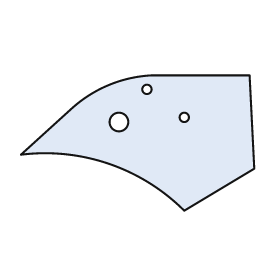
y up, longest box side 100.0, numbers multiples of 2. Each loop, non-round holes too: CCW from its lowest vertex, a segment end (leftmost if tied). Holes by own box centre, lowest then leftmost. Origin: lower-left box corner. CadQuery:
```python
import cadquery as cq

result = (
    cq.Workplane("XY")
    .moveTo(70.0, 0.0)
    .lineTo(100.0, 18.0)
    .lineTo(98.0, 58.0)
    .lineTo(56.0, 58.0)
    .threePointArc((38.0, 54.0), (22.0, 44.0))
    .lineTo(0.0, 24.0)
    .threePointArc((38.0, 20.0), (70.0, 0.0))
    .close()
    .moveTo(42.0, 38.0)
    .circle(4.0)
    .moveTo(70.0, 40.0)
    .circle(2.0)
    .moveTo(54.0, 52.0)
    .circle(2.0)
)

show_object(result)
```